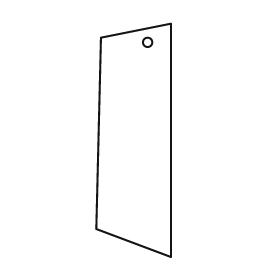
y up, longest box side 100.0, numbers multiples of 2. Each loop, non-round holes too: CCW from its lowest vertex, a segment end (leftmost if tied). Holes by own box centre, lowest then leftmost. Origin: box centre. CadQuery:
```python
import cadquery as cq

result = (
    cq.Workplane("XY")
    .moveTo(16.0, -50.0)
    .lineTo(16.0, 50.0)
    .lineTo(-14.0, 44.0)
    .lineTo(-16.0, -38.0)
    .close()
    .moveTo(6.0, 42.0)
    .circle(2.0)
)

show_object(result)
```